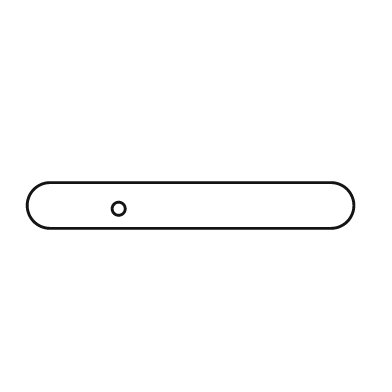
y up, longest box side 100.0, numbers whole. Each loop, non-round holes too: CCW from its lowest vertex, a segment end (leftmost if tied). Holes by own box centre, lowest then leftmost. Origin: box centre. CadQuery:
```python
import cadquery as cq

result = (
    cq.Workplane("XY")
    .moveTo(-43.0, -7.0)
    .lineTo(43.0, -7.0)
    .threePointArc((50.0, 0.0), (43.0, 7.0))
    .lineTo(-43.0, 7.0)
    .threePointArc((-50.0, 0.0), (-43.0, -7.0))
    .close()
    .moveTo(-22.0, -1.0)
    .circle(2.0)
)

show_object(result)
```